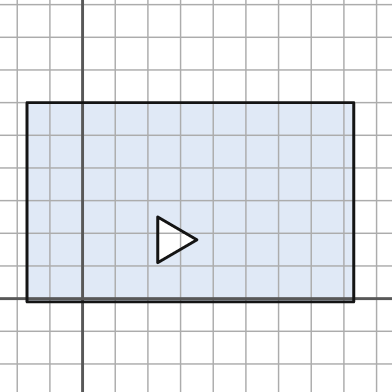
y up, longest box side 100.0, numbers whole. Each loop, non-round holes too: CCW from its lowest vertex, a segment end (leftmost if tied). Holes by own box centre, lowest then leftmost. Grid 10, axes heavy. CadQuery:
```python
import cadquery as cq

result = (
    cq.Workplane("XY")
    .moveTo(-17.0, -1.0)
    .lineTo(83.0, -1.0)
    .lineTo(83.0, 60.0)
    .lineTo(-17.0, 60.0)
    .close()
    .moveTo(23.0, 11.0)
    .lineTo(35.0, 18.0)
    .lineTo(23.0, 25.0)
    .close()
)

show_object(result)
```